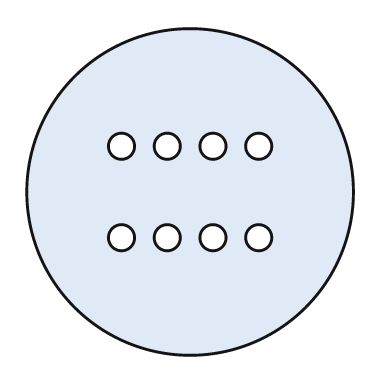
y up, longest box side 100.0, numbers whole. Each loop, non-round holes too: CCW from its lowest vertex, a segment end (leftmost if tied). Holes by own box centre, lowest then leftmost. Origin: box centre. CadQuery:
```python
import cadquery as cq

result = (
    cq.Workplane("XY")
    .moveTo(0.0, 0.0)
    .circle(50.0)
    .moveTo(-21.0, -14.0)
    .circle(4.0)
    .moveTo(-7.0, -14.0)
    .circle(4.0)
    .moveTo(7.0, -14.0)
    .circle(4.0)
    .moveTo(21.0, -14.0)
    .circle(4.0)
    .moveTo(-21.0, 14.0)
    .circle(4.0)
    .moveTo(-7.0, 14.0)
    .circle(4.0)
    .moveTo(7.0, 14.0)
    .circle(4.0)
    .moveTo(21.0, 14.0)
    .circle(4.0)
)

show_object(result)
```